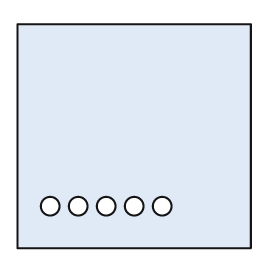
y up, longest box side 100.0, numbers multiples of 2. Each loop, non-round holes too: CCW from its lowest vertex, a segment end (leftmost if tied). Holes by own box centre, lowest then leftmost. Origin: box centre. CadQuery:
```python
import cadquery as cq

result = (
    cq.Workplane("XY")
    .moveTo(-50.0, -48.0)
    .lineTo(50.0, -48.0)
    .lineTo(50.0, 48.0)
    .lineTo(-50.0, 48.0)
    .close()
    .moveTo(-36.0, -30.0)
    .circle(4.0)
    .moveTo(-24.0, -30.0)
    .circle(4.0)
    .moveTo(-12.0, -30.0)
    .circle(4.0)
    .moveTo(0.0, -30.0)
    .circle(4.0)
    .moveTo(12.0, -30.0)
    .circle(4.0)
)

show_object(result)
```